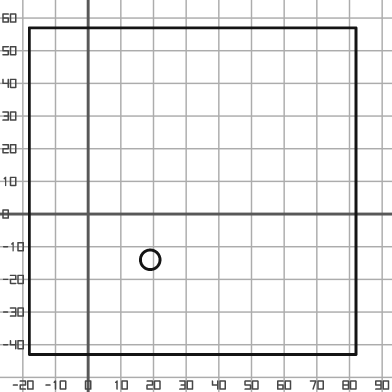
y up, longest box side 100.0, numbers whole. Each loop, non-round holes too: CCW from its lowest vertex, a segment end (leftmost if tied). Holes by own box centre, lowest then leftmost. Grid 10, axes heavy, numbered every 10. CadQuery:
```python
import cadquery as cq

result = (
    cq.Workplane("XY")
    .moveTo(-18.0, -43.0)
    .lineTo(82.0, -43.0)
    .lineTo(82.0, 57.0)
    .lineTo(-18.0, 57.0)
    .close()
    .moveTo(19.0, -14.0)
    .circle(3.0)
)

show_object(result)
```